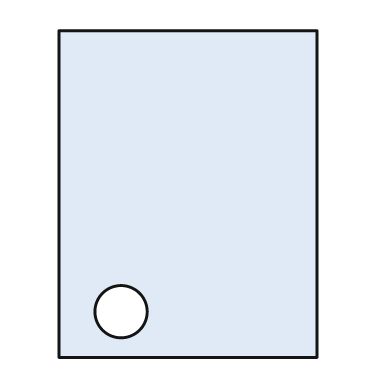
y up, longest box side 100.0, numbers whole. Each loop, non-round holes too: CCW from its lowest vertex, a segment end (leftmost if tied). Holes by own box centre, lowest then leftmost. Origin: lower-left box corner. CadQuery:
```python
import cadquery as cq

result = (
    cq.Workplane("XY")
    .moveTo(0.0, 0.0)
    .lineTo(79.0, 0.0)
    .lineTo(79.0, 100.0)
    .lineTo(0.0, 100.0)
    .close()
    .moveTo(19.0, 14.0)
    .circle(8.0)
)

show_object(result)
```